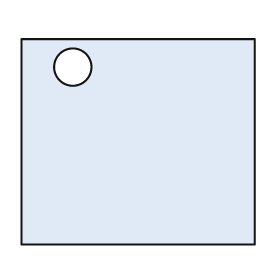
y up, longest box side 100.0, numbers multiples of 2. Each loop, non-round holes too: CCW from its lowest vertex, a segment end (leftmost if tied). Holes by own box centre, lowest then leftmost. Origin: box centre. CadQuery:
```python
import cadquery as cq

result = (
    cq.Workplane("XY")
    .moveTo(-50.0, -44.0)
    .lineTo(50.0, -44.0)
    .lineTo(50.0, 44.0)
    .lineTo(-50.0, 44.0)
    .close()
    .moveTo(-28.0, 32.0)
    .circle(8.0)
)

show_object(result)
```